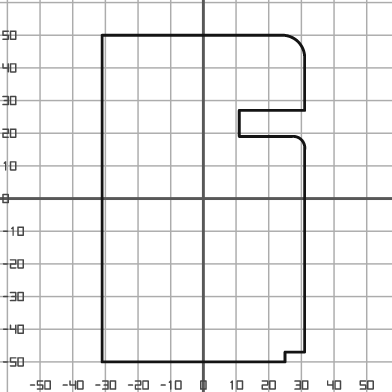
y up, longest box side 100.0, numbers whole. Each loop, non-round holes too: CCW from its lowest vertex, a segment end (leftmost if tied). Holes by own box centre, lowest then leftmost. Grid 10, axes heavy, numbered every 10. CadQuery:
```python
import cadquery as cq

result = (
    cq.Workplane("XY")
    .moveTo(-31.0, -50.0)
    .lineTo(25.0, -50.0)
    .lineTo(25.0, -47.0)
    .lineTo(31.0, -47.0)
    .lineTo(31.0, 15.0)
    .threePointArc((30.0, 18.0), (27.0, 19.0))
    .lineTo(11.0, 19.0)
    .lineTo(11.0, 27.0)
    .lineTo(31.0, 27.0)
    .lineTo(31.0, 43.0)
    .threePointArc((29.0, 48.0), (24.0, 50.0))
    .lineTo(-31.0, 50.0)
    .close()
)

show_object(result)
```